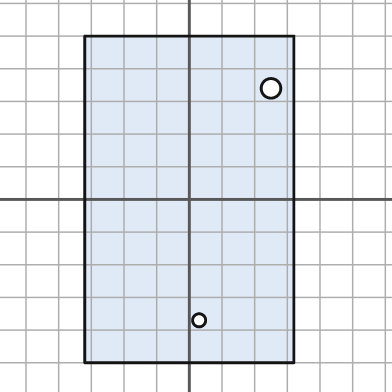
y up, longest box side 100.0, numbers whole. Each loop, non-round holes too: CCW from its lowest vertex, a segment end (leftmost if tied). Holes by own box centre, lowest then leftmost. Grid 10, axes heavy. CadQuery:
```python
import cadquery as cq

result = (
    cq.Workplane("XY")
    .moveTo(-32.0, -50.0)
    .lineTo(32.0, -50.0)
    .lineTo(32.0, 50.0)
    .lineTo(-32.0, 50.0)
    .close()
    .moveTo(3.0, -37.0)
    .circle(2.0)
    .moveTo(25.0, 34.0)
    .circle(3.0)
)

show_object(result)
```